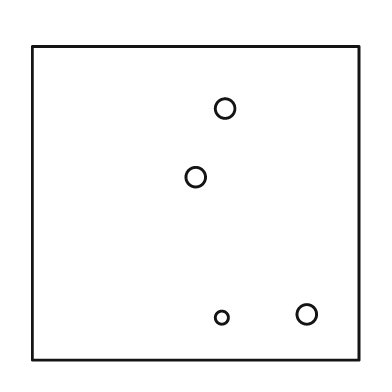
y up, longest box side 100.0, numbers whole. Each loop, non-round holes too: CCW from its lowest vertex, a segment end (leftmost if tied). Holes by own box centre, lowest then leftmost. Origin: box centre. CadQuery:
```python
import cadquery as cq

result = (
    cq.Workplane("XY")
    .moveTo(-50.0, -48.0)
    .lineTo(50.0, -48.0)
    .lineTo(50.0, 48.0)
    .lineTo(-50.0, 48.0)
    .close()
    .moveTo(8.0, -35.0)
    .circle(2.0)
    .moveTo(34.0, -34.0)
    .circle(3.0)
    .moveTo(0.0, 8.0)
    .circle(3.0)
    .moveTo(9.0, 29.0)
    .circle(3.0)
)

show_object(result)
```